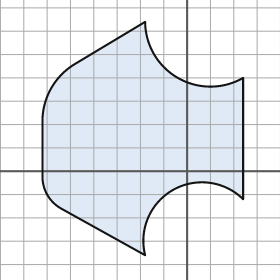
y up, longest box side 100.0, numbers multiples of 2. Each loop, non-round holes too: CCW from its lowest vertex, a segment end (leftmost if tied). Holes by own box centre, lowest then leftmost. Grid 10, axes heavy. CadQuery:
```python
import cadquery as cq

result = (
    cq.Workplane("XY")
    .moveTo(-18.0, -36.0)
    .threePointArc((-6.0, -8.0), (24.0, -12.0))
    .lineTo(24.0, 40.0)
    .threePointArc((-4.0, 40.0), (-18.0, 64.0))
    .lineTo(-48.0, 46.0)
    .threePointArc((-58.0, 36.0), (-62.0, 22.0))
    .lineTo(-62.0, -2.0)
    .threePointArc((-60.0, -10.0), (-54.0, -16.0))
    .close()
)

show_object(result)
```